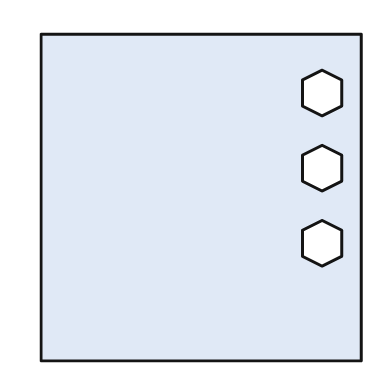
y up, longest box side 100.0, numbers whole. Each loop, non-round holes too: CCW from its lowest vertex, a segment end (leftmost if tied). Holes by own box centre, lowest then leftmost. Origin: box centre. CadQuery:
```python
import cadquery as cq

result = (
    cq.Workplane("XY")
    .moveTo(-49.0, -50.0)
    .lineTo(49.0, -50.0)
    .lineTo(49.0, 50.0)
    .lineTo(-49.0, 50.0)
    .close()
    .moveTo(37.0, -21.0)
    .lineTo(43.0, -18.0)
    .lineTo(43.0, -10.0)
    .lineTo(37.0, -7.0)
    .lineTo(31.0, -10.0)
    .lineTo(31.0, -18.0)
    .close()
    .moveTo(37.0, 2.0)
    .lineTo(43.0, 5.0)
    .lineTo(43.0, 13.0)
    .lineTo(37.0, 16.0)
    .lineTo(31.0, 13.0)
    .lineTo(31.0, 5.0)
    .close()
    .moveTo(37.0, 25.0)
    .lineTo(43.0, 28.0)
    .lineTo(43.0, 36.0)
    .lineTo(37.0, 39.0)
    .lineTo(31.0, 36.0)
    .lineTo(31.0, 28.0)
    .close()
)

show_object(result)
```